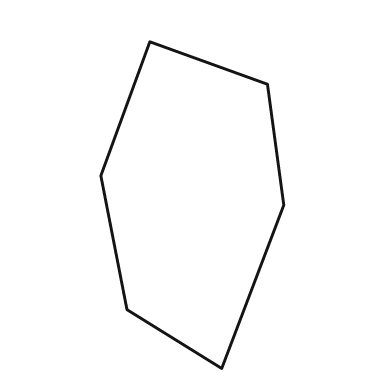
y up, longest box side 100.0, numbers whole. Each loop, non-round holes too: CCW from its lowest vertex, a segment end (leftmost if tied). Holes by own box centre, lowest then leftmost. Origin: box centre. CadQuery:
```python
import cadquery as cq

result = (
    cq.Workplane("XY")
    .moveTo(9.0, -50.0)
    .lineTo(28.0, 0.0)
    .lineTo(23.0, 37.0)
    .lineTo(-13.0, 50.0)
    .lineTo(-28.0, 9.0)
    .lineTo(-20.0, -32.0)
    .close()
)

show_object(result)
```